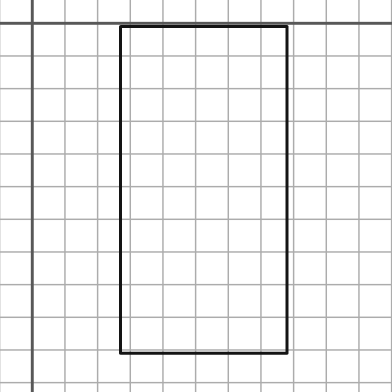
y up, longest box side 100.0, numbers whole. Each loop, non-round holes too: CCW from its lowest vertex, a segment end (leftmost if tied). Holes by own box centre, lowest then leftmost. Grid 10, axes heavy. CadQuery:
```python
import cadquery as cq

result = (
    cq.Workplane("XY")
    .moveTo(27.0, -101.0)
    .lineTo(78.0, -101.0)
    .lineTo(78.0, -1.0)
    .lineTo(27.0, -1.0)
    .close()
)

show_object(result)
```